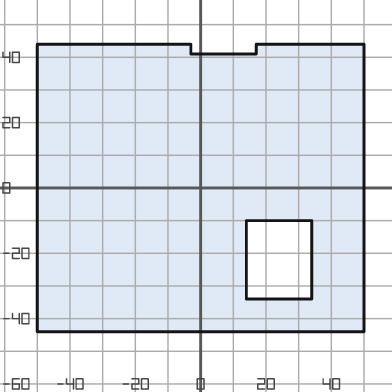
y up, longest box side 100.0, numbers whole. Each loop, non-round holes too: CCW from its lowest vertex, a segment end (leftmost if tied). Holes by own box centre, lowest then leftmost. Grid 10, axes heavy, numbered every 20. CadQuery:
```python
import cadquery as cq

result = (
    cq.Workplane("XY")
    .moveTo(-50.0, -44.0)
    .lineTo(50.0, -44.0)
    .lineTo(50.0, 44.0)
    .lineTo(17.0, 44.0)
    .lineTo(17.0, 41.0)
    .lineTo(-3.0, 41.0)
    .lineTo(-3.0, 44.0)
    .lineTo(-50.0, 44.0)
    .close()
    .moveTo(14.0, -34.0)
    .lineTo(34.0, -34.0)
    .lineTo(34.0, -10.0)
    .lineTo(14.0, -10.0)
    .close()
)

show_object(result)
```